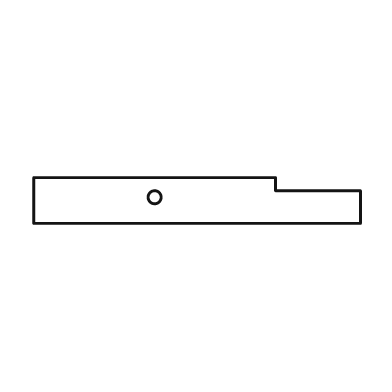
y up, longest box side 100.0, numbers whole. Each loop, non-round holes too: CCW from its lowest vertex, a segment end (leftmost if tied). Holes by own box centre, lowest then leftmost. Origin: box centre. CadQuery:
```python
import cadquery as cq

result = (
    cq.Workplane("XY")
    .moveTo(-50.0, -7.0)
    .lineTo(50.0, -7.0)
    .lineTo(50.0, 3.0)
    .lineTo(24.0, 3.0)
    .lineTo(24.0, 7.0)
    .lineTo(-50.0, 7.0)
    .close()
    .moveTo(-13.0, 1.0)
    .circle(2.0)
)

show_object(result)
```